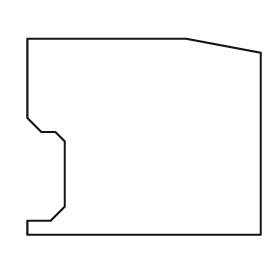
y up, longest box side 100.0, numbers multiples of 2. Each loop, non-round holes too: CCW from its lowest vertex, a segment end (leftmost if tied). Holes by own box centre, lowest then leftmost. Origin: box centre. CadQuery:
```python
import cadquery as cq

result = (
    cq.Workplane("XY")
    .moveTo(-50.0, -42.0)
    .lineTo(50.0, -42.0)
    .lineTo(50.0, 36.0)
    .lineTo(18.0, 42.0)
    .lineTo(-50.0, 42.0)
    .lineTo(-50.0, 8.0)
    .lineTo(-44.0, 2.0)
    .lineTo(-38.0, 2.0)
    .lineTo(-34.0, -2.0)
    .lineTo(-34.0, -30.0)
    .lineTo(-40.0, -36.0)
    .lineTo(-50.0, -36.0)
    .close()
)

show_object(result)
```